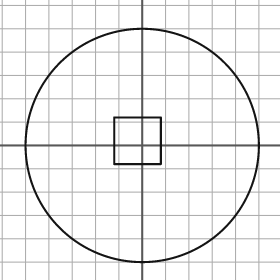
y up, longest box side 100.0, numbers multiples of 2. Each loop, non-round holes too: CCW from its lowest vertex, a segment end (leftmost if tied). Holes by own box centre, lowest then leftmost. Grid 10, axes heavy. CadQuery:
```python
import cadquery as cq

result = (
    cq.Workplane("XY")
    .moveTo(0.0, 0.0)
    .circle(50.0)
    .moveTo(-12.0, -8.0)
    .lineTo(8.0, -8.0)
    .lineTo(8.0, 12.0)
    .lineTo(-12.0, 12.0)
    .close()
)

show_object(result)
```